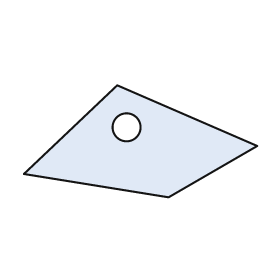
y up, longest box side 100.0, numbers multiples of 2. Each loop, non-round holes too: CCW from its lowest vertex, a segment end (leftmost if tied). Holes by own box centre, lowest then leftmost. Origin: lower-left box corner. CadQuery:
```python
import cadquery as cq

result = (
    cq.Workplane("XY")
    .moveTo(62.0, 0.0)
    .lineTo(100.0, 22.0)
    .lineTo(40.0, 48.0)
    .lineTo(0.0, 10.0)
    .close()
    .moveTo(44.0, 30.0)
    .circle(6.0)
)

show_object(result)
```